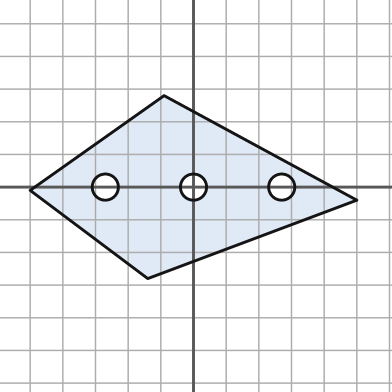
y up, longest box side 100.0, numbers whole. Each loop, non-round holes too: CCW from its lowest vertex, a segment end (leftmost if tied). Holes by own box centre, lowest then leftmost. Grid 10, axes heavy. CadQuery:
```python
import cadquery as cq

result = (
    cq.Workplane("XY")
    .moveTo(-14.0, -28.0)
    .lineTo(50.0, -4.0)
    .lineTo(-9.0, 28.0)
    .lineTo(-50.0, -1.0)
    .close()
    .moveTo(-27.0, 0.0)
    .circle(4.0)
    .moveTo(0.0, 0.0)
    .circle(4.0)
    .moveTo(27.0, 0.0)
    .circle(4.0)
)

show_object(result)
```